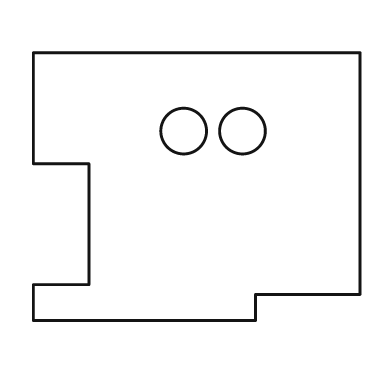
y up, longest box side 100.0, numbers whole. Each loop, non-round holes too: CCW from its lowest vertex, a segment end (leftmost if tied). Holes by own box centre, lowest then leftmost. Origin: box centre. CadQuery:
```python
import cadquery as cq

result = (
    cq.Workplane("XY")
    .moveTo(-50.0, -41.0)
    .lineTo(18.0, -41.0)
    .lineTo(18.0, -33.0)
    .lineTo(50.0, -33.0)
    .lineTo(50.0, 41.0)
    .lineTo(-50.0, 41.0)
    .lineTo(-50.0, 7.0)
    .lineTo(-33.0, 7.0)
    .lineTo(-33.0, -30.0)
    .lineTo(-50.0, -30.0)
    .close()
    .moveTo(-4.0, 17.0)
    .circle(7.0)
    .moveTo(14.0, 17.0)
    .circle(7.0)
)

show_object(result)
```